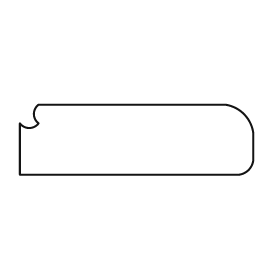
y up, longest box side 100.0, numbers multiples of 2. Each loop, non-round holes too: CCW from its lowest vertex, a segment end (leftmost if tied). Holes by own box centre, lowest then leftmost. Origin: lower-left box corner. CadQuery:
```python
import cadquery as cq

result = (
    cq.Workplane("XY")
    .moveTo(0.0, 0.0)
    .lineTo(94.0, 0.0)
    .threePointArc((98.0, 2.0), (100.0, 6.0))
    .lineTo(100.0, 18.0)
    .threePointArc((96.0, 26.0), (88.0, 30.0))
    .lineTo(8.0, 30.0)
    .threePointArc((6.0, 26.0), (8.0, 22.0))
    .threePointArc((4.0, 20.0), (0.0, 22.0))
    .close()
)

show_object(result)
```